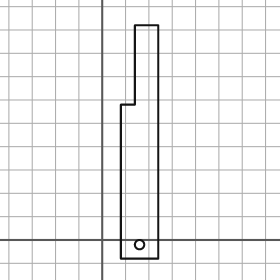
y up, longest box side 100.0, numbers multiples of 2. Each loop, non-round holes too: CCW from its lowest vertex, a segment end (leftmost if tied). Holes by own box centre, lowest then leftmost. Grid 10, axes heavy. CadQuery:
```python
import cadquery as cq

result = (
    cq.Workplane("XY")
    .moveTo(8.0, -8.0)
    .lineTo(24.0, -8.0)
    .lineTo(24.0, 92.0)
    .lineTo(14.0, 92.0)
    .lineTo(14.0, 58.0)
    .lineTo(8.0, 58.0)
    .close()
    .moveTo(16.0, -2.0)
    .circle(2.0)
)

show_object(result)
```